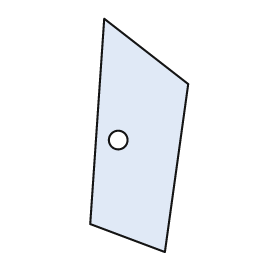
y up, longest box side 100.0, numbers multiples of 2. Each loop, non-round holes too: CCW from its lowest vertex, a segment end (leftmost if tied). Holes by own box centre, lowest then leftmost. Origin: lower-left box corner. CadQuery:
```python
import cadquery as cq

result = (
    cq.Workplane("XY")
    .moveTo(32.0, 0.0)
    .lineTo(42.0, 72.0)
    .lineTo(6.0, 100.0)
    .lineTo(0.0, 12.0)
    .close()
    .moveTo(12.0, 48.0)
    .circle(4.0)
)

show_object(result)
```